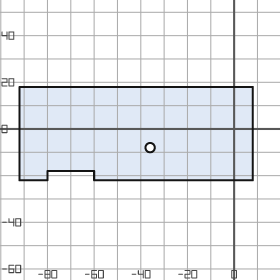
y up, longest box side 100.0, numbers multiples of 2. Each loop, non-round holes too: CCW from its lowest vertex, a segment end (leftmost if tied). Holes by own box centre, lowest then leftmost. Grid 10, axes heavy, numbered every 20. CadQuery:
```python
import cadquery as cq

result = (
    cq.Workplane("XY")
    .moveTo(-92.0, -22.0)
    .lineTo(-80.0, -22.0)
    .lineTo(-80.0, -18.0)
    .lineTo(-60.0, -18.0)
    .lineTo(-60.0, -22.0)
    .lineTo(8.0, -22.0)
    .lineTo(8.0, 18.0)
    .lineTo(-92.0, 18.0)
    .close()
    .moveTo(-36.0, -8.0)
    .circle(2.0)
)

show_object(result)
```